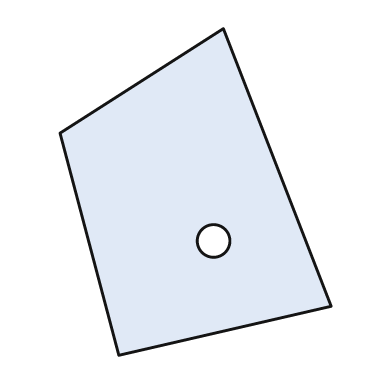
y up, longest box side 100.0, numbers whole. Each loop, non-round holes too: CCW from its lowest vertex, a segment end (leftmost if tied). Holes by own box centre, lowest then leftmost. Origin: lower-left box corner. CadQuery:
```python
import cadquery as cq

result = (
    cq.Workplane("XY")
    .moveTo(18.0, 0.0)
    .lineTo(83.0, 15.0)
    .lineTo(50.0, 100.0)
    .lineTo(0.0, 68.0)
    .close()
    .moveTo(47.0, 35.0)
    .circle(5.0)
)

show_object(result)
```